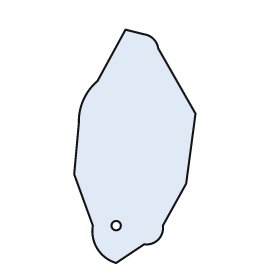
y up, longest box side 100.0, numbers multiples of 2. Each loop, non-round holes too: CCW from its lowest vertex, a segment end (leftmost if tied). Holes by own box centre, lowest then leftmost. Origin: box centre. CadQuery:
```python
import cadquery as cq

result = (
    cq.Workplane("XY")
    .moveTo(-8.0, -50.0)
    .lineTo(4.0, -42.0)
    .threePointArc((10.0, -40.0), (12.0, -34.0))
    .lineTo(22.0, -16.0)
    .lineTo(26.0, 14.0)
    .lineTo(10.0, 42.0)
    .threePointArc((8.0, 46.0), (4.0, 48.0))
    .lineTo(-4.0, 50.0)
    .lineTo(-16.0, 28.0)
    .threePointArc((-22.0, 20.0), (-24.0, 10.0))
    .lineTo(-26.0, -12.0)
    .lineTo(-18.0, -34.0)
    .threePointArc((-16.0, -44.0), (-8.0, -50.0))
    .close()
    .moveTo(-8.0, -34.0)
    .circle(2.0)
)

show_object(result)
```